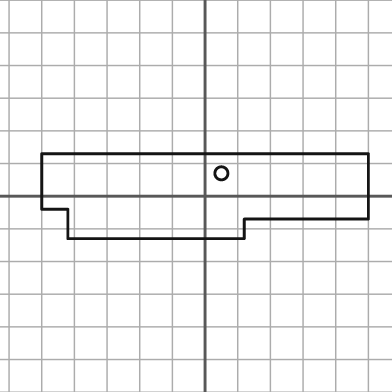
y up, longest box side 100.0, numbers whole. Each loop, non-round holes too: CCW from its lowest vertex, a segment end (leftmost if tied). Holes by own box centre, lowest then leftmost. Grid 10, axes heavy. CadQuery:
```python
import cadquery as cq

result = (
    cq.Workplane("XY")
    .moveTo(-42.0, -13.0)
    .lineTo(12.0, -13.0)
    .lineTo(12.0, -7.0)
    .lineTo(50.0, -7.0)
    .lineTo(50.0, 13.0)
    .lineTo(-50.0, 13.0)
    .lineTo(-50.0, -4.0)
    .lineTo(-42.0, -4.0)
    .close()
    .moveTo(5.0, 7.0)
    .circle(2.0)
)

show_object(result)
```